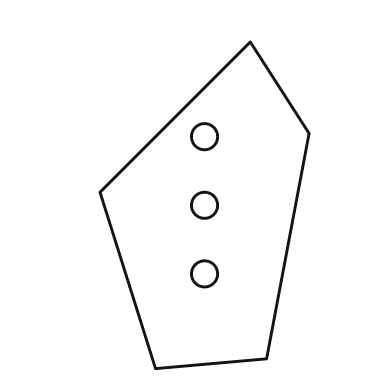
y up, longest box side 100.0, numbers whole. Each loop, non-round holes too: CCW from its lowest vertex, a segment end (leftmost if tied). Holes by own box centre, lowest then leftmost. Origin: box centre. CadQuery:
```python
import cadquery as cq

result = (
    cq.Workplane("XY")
    .moveTo(-15.0, -50.0)
    .lineTo(19.0, -47.0)
    .lineTo(32.0, 22.0)
    .lineTo(14.0, 50.0)
    .lineTo(-32.0, 4.0)
    .close()
    .moveTo(0.0, -21.0)
    .circle(4.0)
    .moveTo(0.0, 0.0)
    .circle(4.0)
    .moveTo(0.0, 21.0)
    .circle(4.0)
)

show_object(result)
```